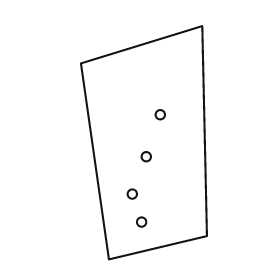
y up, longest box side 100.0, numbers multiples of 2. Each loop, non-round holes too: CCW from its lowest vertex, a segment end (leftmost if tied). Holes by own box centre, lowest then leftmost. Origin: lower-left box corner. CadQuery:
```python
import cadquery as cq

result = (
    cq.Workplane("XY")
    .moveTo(12.0, 0.0)
    .lineTo(54.0, 10.0)
    .lineTo(52.0, 100.0)
    .lineTo(0.0, 84.0)
    .close()
    .moveTo(26.0, 16.0)
    .circle(2.0)
    .moveTo(22.0, 28.0)
    .circle(2.0)
    .moveTo(28.0, 44.0)
    .circle(2.0)
    .moveTo(34.0, 62.0)
    .circle(2.0)
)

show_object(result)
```